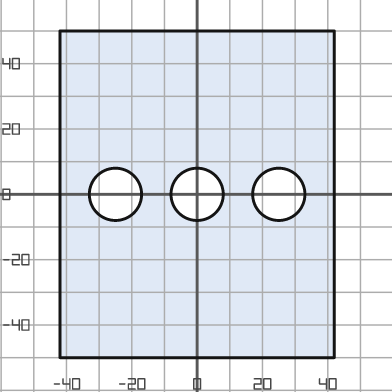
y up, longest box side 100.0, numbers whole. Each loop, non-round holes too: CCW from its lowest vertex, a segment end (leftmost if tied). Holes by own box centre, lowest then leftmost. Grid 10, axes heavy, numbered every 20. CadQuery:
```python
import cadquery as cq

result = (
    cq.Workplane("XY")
    .moveTo(-42.0, -50.0)
    .lineTo(42.0, -50.0)
    .lineTo(42.0, 50.0)
    .lineTo(-42.0, 50.0)
    .close()
    .moveTo(-25.0, 0.0)
    .circle(8.0)
    .moveTo(0.0, 0.0)
    .circle(8.0)
    .moveTo(25.0, 0.0)
    .circle(8.0)
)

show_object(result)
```